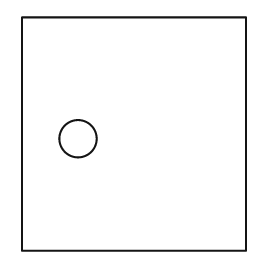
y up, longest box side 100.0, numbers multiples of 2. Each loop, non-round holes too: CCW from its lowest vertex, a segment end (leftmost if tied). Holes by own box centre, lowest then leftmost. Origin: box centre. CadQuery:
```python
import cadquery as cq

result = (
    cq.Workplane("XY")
    .moveTo(-48.0, -50.0)
    .lineTo(48.0, -50.0)
    .lineTo(48.0, 50.0)
    .lineTo(-48.0, 50.0)
    .close()
    .moveTo(-24.0, -2.0)
    .circle(8.0)
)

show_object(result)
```